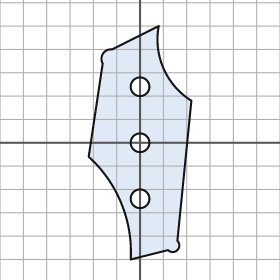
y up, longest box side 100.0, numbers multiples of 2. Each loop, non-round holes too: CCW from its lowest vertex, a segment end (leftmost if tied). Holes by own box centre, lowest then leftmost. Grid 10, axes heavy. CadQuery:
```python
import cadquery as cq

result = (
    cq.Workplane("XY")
    .moveTo(-4.0, -50.0)
    .lineTo(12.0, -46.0)
    .threePointArc((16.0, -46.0), (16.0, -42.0))
    .lineTo(22.0, 18.0)
    .threePointArc((10.0, 32.0), (8.0, 50.0))
    .lineTo(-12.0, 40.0)
    .threePointArc((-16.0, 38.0), (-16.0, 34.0))
    .lineTo(-22.0, -6.0)
    .threePointArc((-8.0, -26.0), (-4.0, -50.0))
    .close()
    .moveTo(0.0, -24.0)
    .circle(4.0)
    .moveTo(0.0, 0.0)
    .circle(4.0)
    .moveTo(0.0, 24.0)
    .circle(4.0)
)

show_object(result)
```